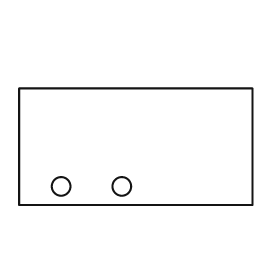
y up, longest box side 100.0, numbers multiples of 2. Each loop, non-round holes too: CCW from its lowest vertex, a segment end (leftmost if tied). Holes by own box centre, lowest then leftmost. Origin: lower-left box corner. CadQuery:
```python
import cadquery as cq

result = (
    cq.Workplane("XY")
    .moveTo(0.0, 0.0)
    .lineTo(100.0, 0.0)
    .lineTo(100.0, 50.0)
    .lineTo(0.0, 50.0)
    .close()
    .moveTo(18.0, 8.0)
    .circle(4.0)
    .moveTo(44.0, 8.0)
    .circle(4.0)
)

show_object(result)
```